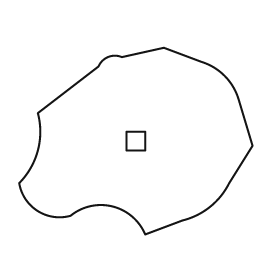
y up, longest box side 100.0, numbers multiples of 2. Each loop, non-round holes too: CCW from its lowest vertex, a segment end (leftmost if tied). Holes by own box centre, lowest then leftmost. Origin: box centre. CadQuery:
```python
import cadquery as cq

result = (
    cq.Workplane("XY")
    .moveTo(4.0, -40.0)
    .lineTo(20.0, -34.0)
    .threePointArc((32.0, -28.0), (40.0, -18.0))
    .lineTo(50.0, -2.0)
    .lineTo(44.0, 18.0)
    .threePointArc((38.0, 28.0), (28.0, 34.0))
    .lineTo(12.0, 40.0)
    .lineTo(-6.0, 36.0)
    .threePointArc((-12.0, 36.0), (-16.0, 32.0))
    .lineTo(-42.0, 12.0)
    .threePointArc((-42.0, -4.0), (-50.0, -18.0))
    .threePointArc((-42.0, -30.0), (-28.0, -32.0))
    .threePointArc((-10.0, -28.0), (4.0, -40.0))
    .close()
    .moveTo(-4.0, -4.0)
    .lineTo(4.0, -4.0)
    .lineTo(4.0, 4.0)
    .lineTo(-4.0, 4.0)
    .close()
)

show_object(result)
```